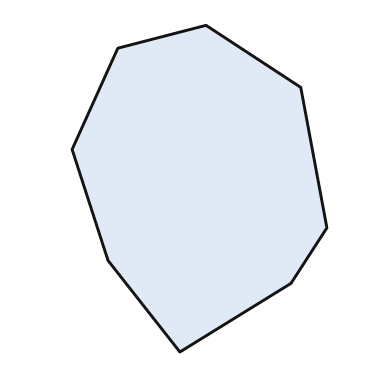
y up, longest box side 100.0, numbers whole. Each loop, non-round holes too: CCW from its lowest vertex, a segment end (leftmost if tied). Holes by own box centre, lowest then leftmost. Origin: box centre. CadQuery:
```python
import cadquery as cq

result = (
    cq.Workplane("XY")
    .moveTo(-6.0, -50.0)
    .lineTo(28.0, -29.0)
    .lineTo(39.0, -12.0)
    .lineTo(31.0, 31.0)
    .lineTo(2.0, 50.0)
    .lineTo(-25.0, 43.0)
    .lineTo(-39.0, 12.0)
    .lineTo(-28.0, -22.0)
    .close()
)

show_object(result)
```